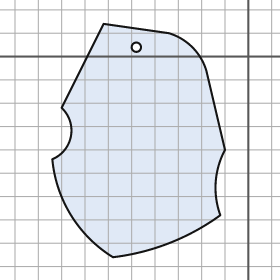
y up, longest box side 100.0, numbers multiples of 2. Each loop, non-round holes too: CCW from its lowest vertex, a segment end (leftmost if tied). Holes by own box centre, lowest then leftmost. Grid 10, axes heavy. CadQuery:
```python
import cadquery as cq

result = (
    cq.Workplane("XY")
    .moveTo(-58.0, -86.0)
    .threePointArc((-34.0, -80.0), (-12.0, -68.0))
    .threePointArc((-14.0, -54.0), (-10.0, -40.0))
    .lineTo(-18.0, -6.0)
    .threePointArc((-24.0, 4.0), (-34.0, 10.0))
    .lineTo(-62.0, 14.0)
    .lineTo(-80.0, -22.0)
    .threePointArc((-76.0, -34.0), (-84.0, -44.0))
    .threePointArc((-76.0, -68.0), (-58.0, -86.0))
    .close()
    .moveTo(-48.0, 4.0)
    .circle(2.0)
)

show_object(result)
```